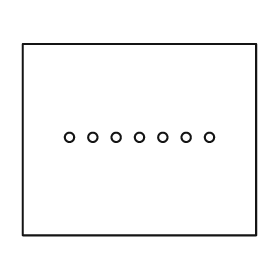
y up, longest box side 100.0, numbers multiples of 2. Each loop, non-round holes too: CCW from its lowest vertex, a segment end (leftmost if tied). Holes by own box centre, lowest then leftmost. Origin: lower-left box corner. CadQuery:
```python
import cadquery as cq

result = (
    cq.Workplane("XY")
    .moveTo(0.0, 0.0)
    .lineTo(100.0, 0.0)
    .lineTo(100.0, 82.0)
    .lineTo(0.0, 82.0)
    .close()
    .moveTo(20.0, 42.0)
    .circle(2.0)
    .moveTo(30.0, 42.0)
    .circle(2.0)
    .moveTo(40.0, 42.0)
    .circle(2.0)
    .moveTo(50.0, 42.0)
    .circle(2.0)
    .moveTo(60.0, 42.0)
    .circle(2.0)
    .moveTo(70.0, 42.0)
    .circle(2.0)
    .moveTo(80.0, 42.0)
    .circle(2.0)
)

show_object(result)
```